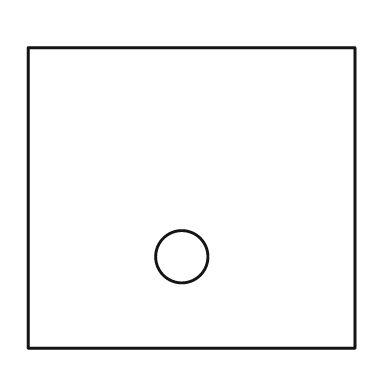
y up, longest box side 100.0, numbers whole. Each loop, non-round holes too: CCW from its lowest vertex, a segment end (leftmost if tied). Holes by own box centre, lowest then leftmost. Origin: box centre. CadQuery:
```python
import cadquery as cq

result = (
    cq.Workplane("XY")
    .moveTo(-50.0, -46.0)
    .lineTo(50.0, -46.0)
    .lineTo(50.0, 46.0)
    .lineTo(-50.0, 46.0)
    .close()
    .moveTo(-3.0, -18.0)
    .circle(8.0)
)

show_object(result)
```